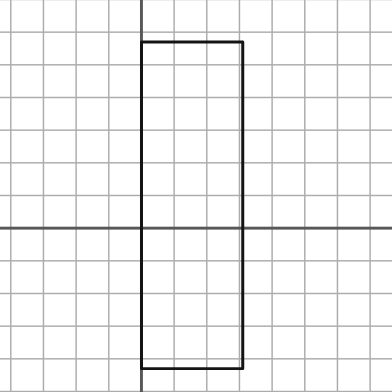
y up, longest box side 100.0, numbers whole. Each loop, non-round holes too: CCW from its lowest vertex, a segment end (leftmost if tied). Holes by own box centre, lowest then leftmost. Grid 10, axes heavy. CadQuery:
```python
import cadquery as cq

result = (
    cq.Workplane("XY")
    .moveTo(0.0, -43.0)
    .lineTo(31.0, -43.0)
    .lineTo(31.0, 57.0)
    .lineTo(0.0, 57.0)
    .close()
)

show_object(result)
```